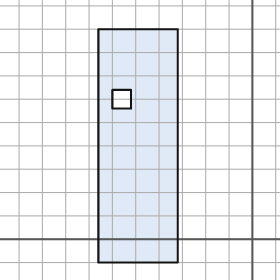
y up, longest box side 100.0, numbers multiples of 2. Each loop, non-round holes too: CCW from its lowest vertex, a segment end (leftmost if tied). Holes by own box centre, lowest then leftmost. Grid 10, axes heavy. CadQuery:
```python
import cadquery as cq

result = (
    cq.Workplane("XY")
    .moveTo(-66.0, -10.0)
    .lineTo(-32.0, -10.0)
    .lineTo(-32.0, 90.0)
    .lineTo(-66.0, 90.0)
    .close()
    .moveTo(-60.0, 56.0)
    .lineTo(-52.0, 56.0)
    .lineTo(-52.0, 64.0)
    .lineTo(-60.0, 64.0)
    .close()
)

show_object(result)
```